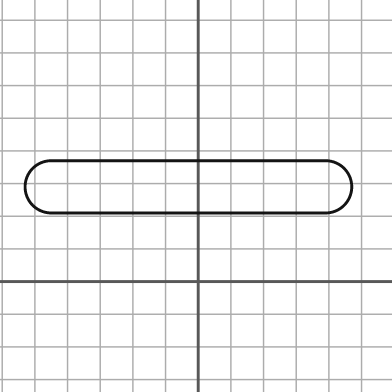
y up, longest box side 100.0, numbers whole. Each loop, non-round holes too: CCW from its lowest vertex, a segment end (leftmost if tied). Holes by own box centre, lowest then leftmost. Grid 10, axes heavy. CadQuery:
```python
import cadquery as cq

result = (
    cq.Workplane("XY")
    .moveTo(-45.0, 21.0)
    .lineTo(39.0, 21.0)
    .threePointArc((47.0, 29.0), (39.0, 37.0))
    .lineTo(-45.0, 37.0)
    .threePointArc((-53.0, 29.0), (-45.0, 21.0))
    .close()
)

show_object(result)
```